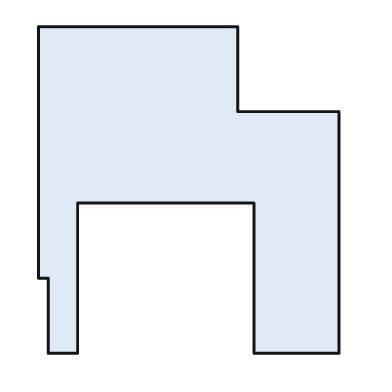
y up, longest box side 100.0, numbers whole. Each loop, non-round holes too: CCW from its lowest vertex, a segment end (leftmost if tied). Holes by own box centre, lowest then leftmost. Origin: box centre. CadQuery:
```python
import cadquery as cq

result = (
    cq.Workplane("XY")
    .moveTo(-43.0, -50.0)
    .lineTo(-34.0, -50.0)
    .lineTo(-34.0, -4.0)
    .lineTo(20.0, -4.0)
    .lineTo(20.0, -50.0)
    .lineTo(46.0, -50.0)
    .lineTo(46.0, 24.0)
    .lineTo(15.0, 24.0)
    .lineTo(15.0, 50.0)
    .lineTo(-46.0, 50.0)
    .lineTo(-46.0, -27.0)
    .lineTo(-43.0, -27.0)
    .close()
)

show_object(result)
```